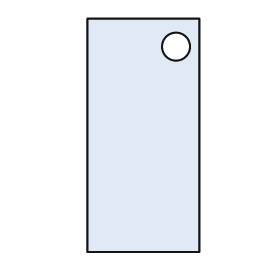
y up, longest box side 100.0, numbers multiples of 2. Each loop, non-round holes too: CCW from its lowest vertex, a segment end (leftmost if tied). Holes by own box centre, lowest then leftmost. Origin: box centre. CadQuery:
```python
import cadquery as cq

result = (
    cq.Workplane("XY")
    .moveTo(-24.0, -50.0)
    .lineTo(24.0, -50.0)
    .lineTo(24.0, 50.0)
    .lineTo(-24.0, 50.0)
    .close()
    .moveTo(14.0, 38.0)
    .circle(6.0)
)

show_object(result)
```